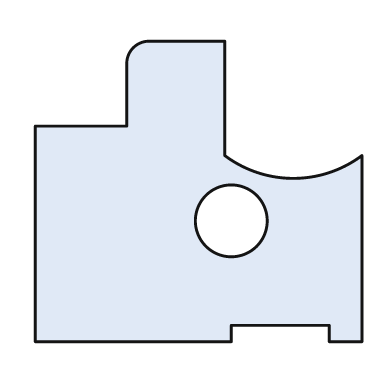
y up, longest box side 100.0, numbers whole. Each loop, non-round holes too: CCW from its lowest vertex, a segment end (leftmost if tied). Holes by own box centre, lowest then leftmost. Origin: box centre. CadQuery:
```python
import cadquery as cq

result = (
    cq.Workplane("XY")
    .moveTo(-50.0, -46.0)
    .lineTo(10.0, -46.0)
    .lineTo(10.0, -41.0)
    .lineTo(40.0, -41.0)
    .lineTo(40.0, -46.0)
    .lineTo(50.0, -46.0)
    .lineTo(50.0, 11.0)
    .threePointArc((29.0, 4.0), (8.0, 11.0))
    .lineTo(8.0, 46.0)
    .lineTo(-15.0, 46.0)
    .threePointArc((-20.0, 44.0), (-22.0, 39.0))
    .lineTo(-22.0, 20.0)
    .lineTo(-50.0, 20.0)
    .close()
    .moveTo(10.0, -9.0)
    .circle(11.0)
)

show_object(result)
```